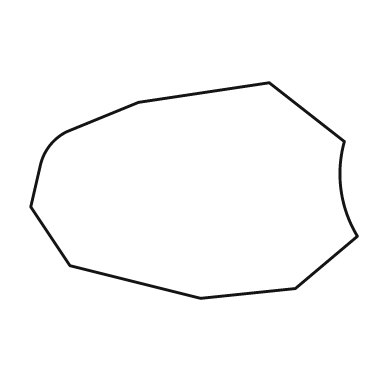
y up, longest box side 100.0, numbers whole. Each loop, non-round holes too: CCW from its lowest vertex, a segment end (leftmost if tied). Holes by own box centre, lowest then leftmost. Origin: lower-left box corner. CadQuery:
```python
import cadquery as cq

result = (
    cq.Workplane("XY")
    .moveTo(52.0, 0.0)
    .lineTo(81.0, 3.0)
    .lineTo(100.0, 19.0)
    .threePointArc((95.0, 33.0), (96.0, 48.0))
    .lineTo(73.0, 66.0)
    .lineTo(33.0, 60.0)
    .lineTo(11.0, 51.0)
    .threePointArc((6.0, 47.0), (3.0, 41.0))
    .lineTo(0.0, 28.0)
    .lineTo(12.0, 10.0)
    .close()
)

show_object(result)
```